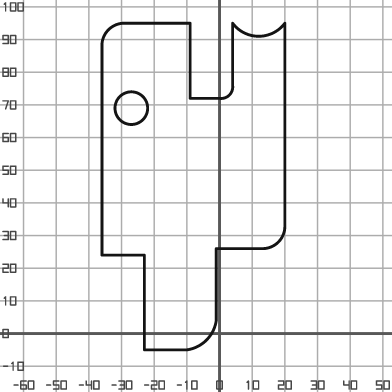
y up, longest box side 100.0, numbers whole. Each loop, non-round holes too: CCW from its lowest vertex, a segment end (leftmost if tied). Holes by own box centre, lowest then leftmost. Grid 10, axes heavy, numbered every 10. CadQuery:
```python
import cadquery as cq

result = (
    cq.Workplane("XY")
    .moveTo(-23.0, -5.0)
    .lineTo(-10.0, -5.0)
    .threePointArc((-4.0, -2.0), (-1.0, 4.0))
    .lineTo(-1.0, 26.0)
    .lineTo(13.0, 26.0)
    .threePointArc((18.0, 28.0), (20.0, 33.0))
    .lineTo(20.0, 95.0)
    .threePointArc((12.0, 91.0), (4.0, 95.0))
    .lineTo(4.0, 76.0)
    .threePointArc((3.0, 73.0), (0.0, 72.0))
    .lineTo(-9.0, 72.0)
    .lineTo(-9.0, 95.0)
    .lineTo(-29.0, 95.0)
    .threePointArc((-34.0, 93.0), (-36.0, 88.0))
    .lineTo(-36.0, 24.0)
    .lineTo(-23.0, 24.0)
    .close()
    .moveTo(-27.0, 69.0)
    .circle(5.0)
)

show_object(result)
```